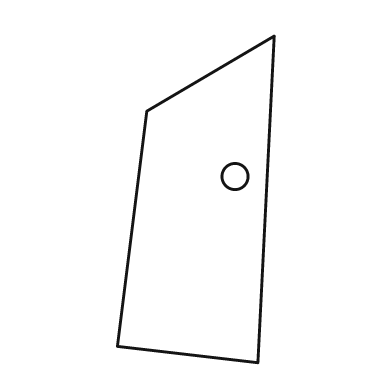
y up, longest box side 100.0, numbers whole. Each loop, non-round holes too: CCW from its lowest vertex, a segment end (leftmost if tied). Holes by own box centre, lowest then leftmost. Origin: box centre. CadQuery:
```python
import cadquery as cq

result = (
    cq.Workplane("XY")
    .moveTo(19.0, -50.0)
    .lineTo(24.0, 50.0)
    .lineTo(-15.0, 27.0)
    .lineTo(-24.0, -45.0)
    .close()
    .moveTo(12.0, 7.0)
    .circle(4.0)
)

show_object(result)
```